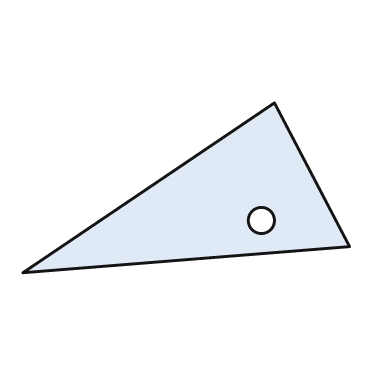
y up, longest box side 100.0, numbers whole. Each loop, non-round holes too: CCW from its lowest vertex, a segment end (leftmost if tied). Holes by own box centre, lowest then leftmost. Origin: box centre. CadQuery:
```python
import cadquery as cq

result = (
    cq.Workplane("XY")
    .moveTo(-50.0, -26.0)
    .lineTo(50.0, -18.0)
    .lineTo(27.0, 26.0)
    .close()
    .moveTo(23.0, -10.0)
    .circle(4.0)
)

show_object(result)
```